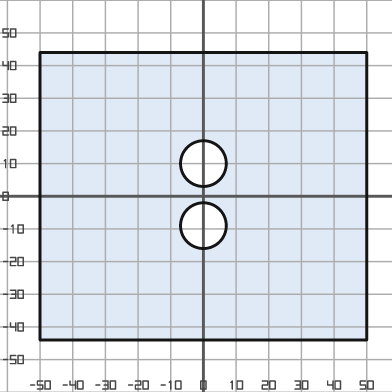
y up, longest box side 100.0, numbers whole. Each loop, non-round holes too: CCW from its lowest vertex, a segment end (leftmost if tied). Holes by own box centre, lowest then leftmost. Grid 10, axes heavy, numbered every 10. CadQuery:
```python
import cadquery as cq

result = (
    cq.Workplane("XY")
    .moveTo(-50.0, -44.0)
    .lineTo(50.0, -44.0)
    .lineTo(50.0, 44.0)
    .lineTo(-50.0, 44.0)
    .close()
    .moveTo(0.0, -9.0)
    .circle(7.0)
    .moveTo(0.0, 10.0)
    .circle(7.0)
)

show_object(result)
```